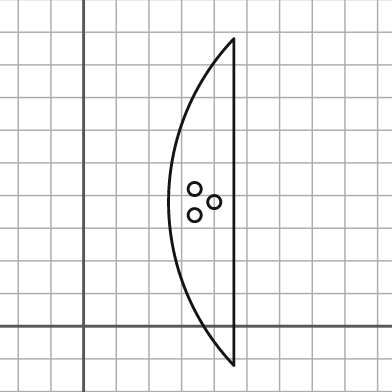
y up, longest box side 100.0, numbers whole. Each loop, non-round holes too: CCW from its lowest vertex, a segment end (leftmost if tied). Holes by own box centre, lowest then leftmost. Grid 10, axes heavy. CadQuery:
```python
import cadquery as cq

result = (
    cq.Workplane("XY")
    .moveTo(46.0, -12.0)
    .lineTo(46.0, 88.0)
    .threePointArc((26.0, 38.0), (46.0, -12.0))
    .close()
    .moveTo(34.0, 34.0)
    .circle(2.0)
    .moveTo(40.0, 38.0)
    .circle(2.0)
    .moveTo(34.0, 42.0)
    .circle(2.0)
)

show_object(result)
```